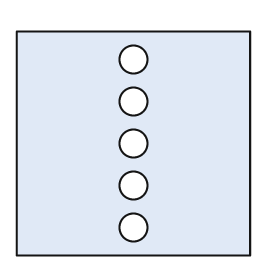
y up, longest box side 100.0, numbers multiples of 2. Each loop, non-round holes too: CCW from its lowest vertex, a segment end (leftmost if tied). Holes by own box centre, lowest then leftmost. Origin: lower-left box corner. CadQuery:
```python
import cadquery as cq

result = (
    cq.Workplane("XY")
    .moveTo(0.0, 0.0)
    .lineTo(100.0, 0.0)
    .lineTo(100.0, 96.0)
    .lineTo(0.0, 96.0)
    .close()
    .moveTo(50.0, 12.0)
    .circle(6.0)
    .moveTo(50.0, 30.0)
    .circle(6.0)
    .moveTo(50.0, 48.0)
    .circle(6.0)
    .moveTo(50.0, 66.0)
    .circle(6.0)
    .moveTo(50.0, 84.0)
    .circle(6.0)
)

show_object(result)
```